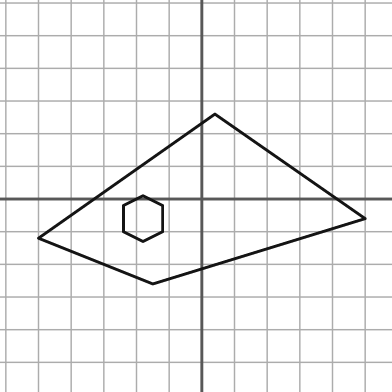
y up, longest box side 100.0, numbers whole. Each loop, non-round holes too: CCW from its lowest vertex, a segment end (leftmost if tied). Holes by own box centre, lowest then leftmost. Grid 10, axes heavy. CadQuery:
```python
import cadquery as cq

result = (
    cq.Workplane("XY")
    .moveTo(-15.0, -26.0)
    .lineTo(50.0, -6.0)
    .lineTo(4.0, 26.0)
    .lineTo(-50.0, -12.0)
    .close()
    .moveTo(-18.0, -13.0)
    .lineTo(-12.0, -10.0)
    .lineTo(-12.0, -2.0)
    .lineTo(-18.0, 1.0)
    .lineTo(-24.0, -2.0)
    .lineTo(-24.0, -10.0)
    .close()
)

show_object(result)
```